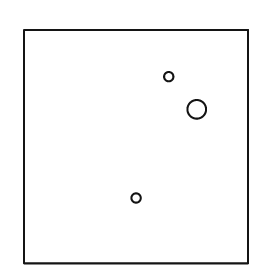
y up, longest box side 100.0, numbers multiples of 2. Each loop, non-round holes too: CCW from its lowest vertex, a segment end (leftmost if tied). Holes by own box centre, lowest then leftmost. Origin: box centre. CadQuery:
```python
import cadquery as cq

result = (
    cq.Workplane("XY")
    .moveTo(-48.0, -50.0)
    .lineTo(48.0, -50.0)
    .lineTo(48.0, 50.0)
    .lineTo(-48.0, 50.0)
    .close()
    .moveTo(0.0, -22.0)
    .circle(2.0)
    .moveTo(26.0, 16.0)
    .circle(4.0)
    .moveTo(14.0, 30.0)
    .circle(2.0)
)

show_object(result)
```